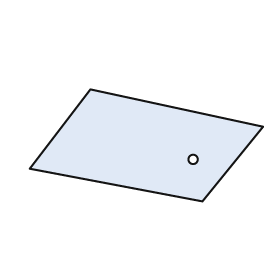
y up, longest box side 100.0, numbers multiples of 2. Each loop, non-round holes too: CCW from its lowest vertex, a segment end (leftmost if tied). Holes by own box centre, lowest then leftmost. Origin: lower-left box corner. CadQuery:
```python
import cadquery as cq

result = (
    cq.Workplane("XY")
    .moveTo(74.0, 0.0)
    .lineTo(100.0, 32.0)
    .lineTo(26.0, 48.0)
    .lineTo(0.0, 14.0)
    .close()
    .moveTo(70.0, 18.0)
    .circle(2.0)
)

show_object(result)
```